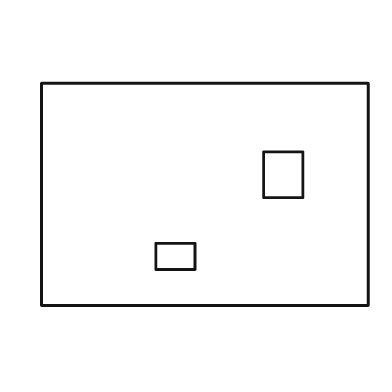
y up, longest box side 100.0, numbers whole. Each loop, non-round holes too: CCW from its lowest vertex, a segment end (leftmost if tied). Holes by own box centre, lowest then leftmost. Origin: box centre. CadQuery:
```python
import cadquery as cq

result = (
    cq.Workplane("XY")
    .moveTo(-50.0, -34.0)
    .lineTo(50.0, -34.0)
    .lineTo(50.0, 34.0)
    .lineTo(-50.0, 34.0)
    .close()
    .moveTo(-15.0, -23.0)
    .lineTo(-3.0, -23.0)
    .lineTo(-3.0, -15.0)
    .lineTo(-15.0, -15.0)
    .close()
    .moveTo(18.0, -1.0)
    .lineTo(30.0, -1.0)
    .lineTo(30.0, 13.0)
    .lineTo(18.0, 13.0)
    .close()
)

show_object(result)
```